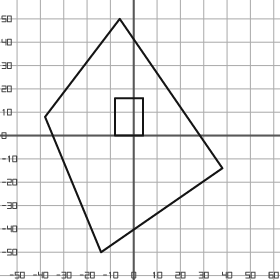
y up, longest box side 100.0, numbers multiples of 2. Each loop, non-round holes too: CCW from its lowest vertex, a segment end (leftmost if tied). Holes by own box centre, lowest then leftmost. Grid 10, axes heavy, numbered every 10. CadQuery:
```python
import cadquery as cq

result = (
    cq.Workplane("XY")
    .moveTo(-14.0, -50.0)
    .lineTo(38.0, -14.0)
    .lineTo(-6.0, 50.0)
    .lineTo(-38.0, 8.0)
    .close()
    .moveTo(-8.0, 0.0)
    .lineTo(4.0, 0.0)
    .lineTo(4.0, 16.0)
    .lineTo(-8.0, 16.0)
    .close()
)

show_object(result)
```